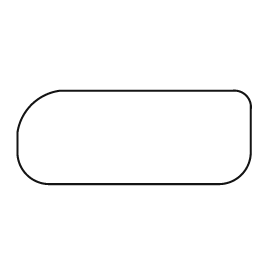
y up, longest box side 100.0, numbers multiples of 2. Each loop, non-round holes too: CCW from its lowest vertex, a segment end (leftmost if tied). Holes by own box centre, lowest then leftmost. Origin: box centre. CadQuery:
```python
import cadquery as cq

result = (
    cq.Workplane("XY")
    .moveTo(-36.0, -20.0)
    .lineTo(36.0, -20.0)
    .threePointArc((46.0, -16.0), (50.0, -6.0))
    .lineTo(50.0, 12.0)
    .threePointArc((48.0, 18.0), (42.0, 20.0))
    .lineTo(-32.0, 20.0)
    .threePointArc((-44.0, 14.0), (-50.0, 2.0))
    .lineTo(-50.0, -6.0)
    .threePointArc((-46.0, -16.0), (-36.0, -20.0))
    .close()
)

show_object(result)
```